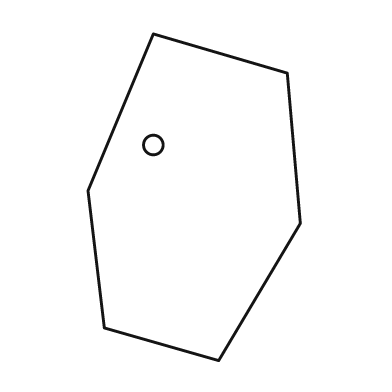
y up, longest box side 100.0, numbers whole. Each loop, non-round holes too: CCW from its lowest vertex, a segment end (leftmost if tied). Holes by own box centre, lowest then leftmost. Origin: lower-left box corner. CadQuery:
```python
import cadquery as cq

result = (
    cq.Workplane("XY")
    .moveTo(40.0, 0.0)
    .lineTo(65.0, 42.0)
    .lineTo(61.0, 88.0)
    .lineTo(20.0, 100.0)
    .lineTo(0.0, 52.0)
    .lineTo(5.0, 10.0)
    .close()
    .moveTo(20.0, 66.0)
    .circle(3.0)
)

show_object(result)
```